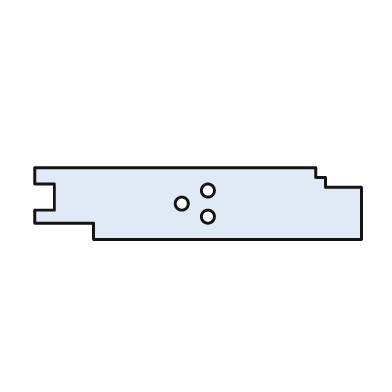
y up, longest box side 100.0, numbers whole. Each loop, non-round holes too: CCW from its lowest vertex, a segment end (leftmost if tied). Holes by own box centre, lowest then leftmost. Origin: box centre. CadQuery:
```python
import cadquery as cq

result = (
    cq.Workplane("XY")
    .moveTo(-32.0, -11.0)
    .lineTo(50.0, -11.0)
    .lineTo(50.0, 5.0)
    .lineTo(39.0, 5.0)
    .lineTo(39.0, 8.0)
    .lineTo(36.0, 8.0)
    .lineTo(36.0, 11.0)
    .lineTo(-50.0, 11.0)
    .lineTo(-50.0, 6.0)
    .lineTo(-44.0, 6.0)
    .lineTo(-44.0, -2.0)
    .lineTo(-50.0, -2.0)
    .lineTo(-50.0, -6.0)
    .lineTo(-32.0, -6.0)
    .close()
    .moveTo(3.0, -4.0)
    .circle(2.0)
    .moveTo(-5.0, 0.0)
    .circle(2.0)
    .moveTo(3.0, 4.0)
    .circle(2.0)
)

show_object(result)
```